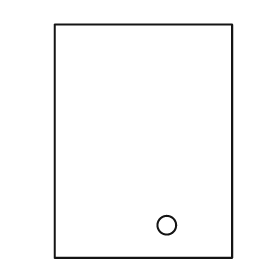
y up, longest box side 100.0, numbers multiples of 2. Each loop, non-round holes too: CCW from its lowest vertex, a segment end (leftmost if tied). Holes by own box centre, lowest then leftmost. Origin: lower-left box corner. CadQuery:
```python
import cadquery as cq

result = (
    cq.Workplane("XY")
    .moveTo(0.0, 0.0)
    .lineTo(76.0, 0.0)
    .lineTo(76.0, 100.0)
    .lineTo(0.0, 100.0)
    .close()
    .moveTo(48.0, 14.0)
    .circle(4.0)
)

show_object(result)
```